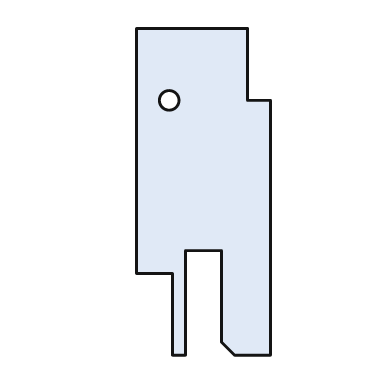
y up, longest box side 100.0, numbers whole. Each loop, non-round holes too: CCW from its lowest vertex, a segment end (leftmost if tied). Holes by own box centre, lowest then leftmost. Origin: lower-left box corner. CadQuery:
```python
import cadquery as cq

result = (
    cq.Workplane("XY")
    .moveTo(11.0, 0.0)
    .lineTo(15.0, 0.0)
    .lineTo(15.0, 32.0)
    .lineTo(26.0, 32.0)
    .lineTo(26.0, 4.0)
    .lineTo(30.0, 0.0)
    .lineTo(41.0, 0.0)
    .lineTo(41.0, 78.0)
    .lineTo(34.0, 78.0)
    .lineTo(34.0, 100.0)
    .lineTo(0.0, 100.0)
    .lineTo(0.0, 25.0)
    .lineTo(11.0, 25.0)
    .close()
    .moveTo(10.0, 78.0)
    .circle(3.0)
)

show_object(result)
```